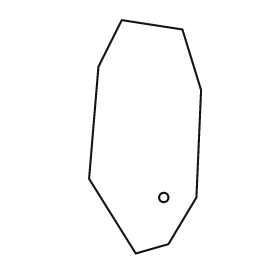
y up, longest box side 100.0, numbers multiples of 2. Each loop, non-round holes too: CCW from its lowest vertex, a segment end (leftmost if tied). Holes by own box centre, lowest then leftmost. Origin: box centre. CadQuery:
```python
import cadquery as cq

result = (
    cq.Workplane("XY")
    .moveTo(-4.0, -50.0)
    .lineTo(10.0, -46.0)
    .lineTo(22.0, -26.0)
    .lineTo(24.0, 20.0)
    .lineTo(16.0, 46.0)
    .lineTo(-10.0, 50.0)
    .lineTo(-20.0, 30.0)
    .lineTo(-24.0, -18.0)
    .close()
    .moveTo(8.0, -26.0)
    .circle(2.0)
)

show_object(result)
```